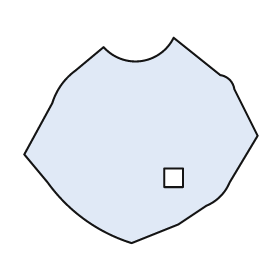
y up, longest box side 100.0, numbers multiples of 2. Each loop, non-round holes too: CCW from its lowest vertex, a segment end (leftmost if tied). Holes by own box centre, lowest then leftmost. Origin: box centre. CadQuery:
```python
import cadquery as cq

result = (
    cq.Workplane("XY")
    .moveTo(-4.0, -44.0)
    .lineTo(16.0, -36.0)
    .lineTo(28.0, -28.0)
    .threePointArc((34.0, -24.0), (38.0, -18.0))
    .lineTo(50.0, 2.0)
    .lineTo(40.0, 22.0)
    .threePointArc((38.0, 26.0), (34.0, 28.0))
    .lineTo(14.0, 44.0)
    .threePointArc((0.0, 34.0), (-16.0, 40.0))
    .lineTo(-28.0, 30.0)
    .threePointArc((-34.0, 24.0), (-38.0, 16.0))
    .lineTo(-50.0, -6.0)
    .lineTo(-40.0, -18.0)
    .threePointArc((-24.0, -34.0), (-4.0, -44.0))
    .close()
    .moveTo(10.0, -20.0)
    .lineTo(18.0, -20.0)
    .lineTo(18.0, -12.0)
    .lineTo(10.0, -12.0)
    .close()
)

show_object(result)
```